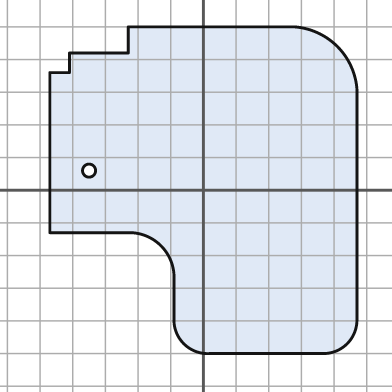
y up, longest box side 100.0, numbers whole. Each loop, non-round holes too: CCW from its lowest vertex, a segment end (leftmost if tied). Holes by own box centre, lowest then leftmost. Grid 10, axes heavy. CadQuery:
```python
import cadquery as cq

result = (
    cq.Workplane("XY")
    .moveTo(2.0, -50.0)
    .lineTo(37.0, -50.0)
    .threePointArc((44.0, -47.0), (47.0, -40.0))
    .lineTo(47.0, 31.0)
    .threePointArc((41.0, 44.0), (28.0, 50.0))
    .lineTo(-23.0, 50.0)
    .lineTo(-23.0, 42.0)
    .lineTo(-41.0, 42.0)
    .lineTo(-41.0, 36.0)
    .lineTo(-47.0, 36.0)
    .lineTo(-47.0, -13.0)
    .lineTo(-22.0, -13.0)
    .threePointArc((-13.0, -17.0), (-9.0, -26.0))
    .lineTo(-9.0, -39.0)
    .threePointArc((-6.0, -47.0), (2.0, -50.0))
    .close()
    .moveTo(-35.0, 6.0)
    .circle(2.0)
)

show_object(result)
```